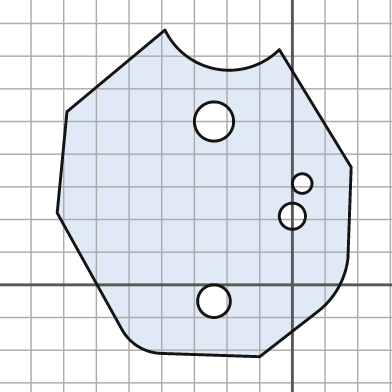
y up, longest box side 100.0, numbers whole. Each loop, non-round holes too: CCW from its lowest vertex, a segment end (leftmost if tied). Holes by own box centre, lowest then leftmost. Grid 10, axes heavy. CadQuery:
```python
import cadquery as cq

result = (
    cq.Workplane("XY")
    .moveTo(-10.0, -22.0)
    .lineTo(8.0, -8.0)
    .threePointArc((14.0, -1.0), (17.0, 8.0))
    .lineTo(18.0, 36.0)
    .lineTo(-4.0, 72.0)
    .threePointArc((-23.0, 66.0), (-39.0, 78.0))
    .lineTo(-69.0, 53.0)
    .lineTo(-72.0, 22.0)
    .lineTo(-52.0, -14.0)
    .threePointArc((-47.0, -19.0), (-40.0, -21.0))
    .close()
    .moveTo(-24.0, -5.0)
    .circle(5.0)
    .moveTo(0.0, 21.0)
    .circle(4.0)
    .moveTo(3.0, 31.0)
    .circle(3.0)
    .moveTo(-24.0, 50.0)
    .circle(6.0)
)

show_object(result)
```